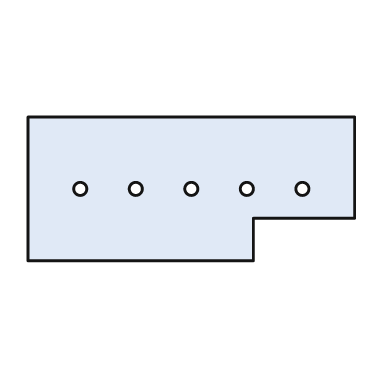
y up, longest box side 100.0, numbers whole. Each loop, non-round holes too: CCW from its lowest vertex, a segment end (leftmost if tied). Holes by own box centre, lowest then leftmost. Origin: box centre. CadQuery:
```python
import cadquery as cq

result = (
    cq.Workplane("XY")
    .moveTo(-50.0, -22.0)
    .lineTo(19.0, -22.0)
    .lineTo(19.0, -9.0)
    .lineTo(50.0, -9.0)
    .lineTo(50.0, 22.0)
    .lineTo(-50.0, 22.0)
    .close()
    .moveTo(-34.0, 0.0)
    .circle(2.0)
    .moveTo(-17.0, 0.0)
    .circle(2.0)
    .moveTo(0.0, 0.0)
    .circle(2.0)
    .moveTo(17.0, 0.0)
    .circle(2.0)
    .moveTo(34.0, 0.0)
    .circle(2.0)
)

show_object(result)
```